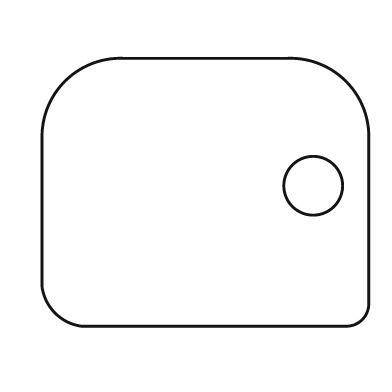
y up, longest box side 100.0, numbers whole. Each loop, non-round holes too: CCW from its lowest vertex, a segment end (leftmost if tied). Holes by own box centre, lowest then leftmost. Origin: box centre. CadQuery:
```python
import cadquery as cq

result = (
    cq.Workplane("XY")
    .moveTo(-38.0, -41.0)
    .lineTo(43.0, -41.0)
    .threePointArc((48.0, -39.0), (50.0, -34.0))
    .lineTo(50.0, 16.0)
    .threePointArc((43.0, 34.0), (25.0, 41.0))
    .lineTo(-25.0, 41.0)
    .threePointArc((-43.0, 34.0), (-50.0, 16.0))
    .lineTo(-50.0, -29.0)
    .threePointArc((-46.0, -37.0), (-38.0, -41.0))
    .close()
    .moveTo(33.0, 2.0)
    .circle(9.0)
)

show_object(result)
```